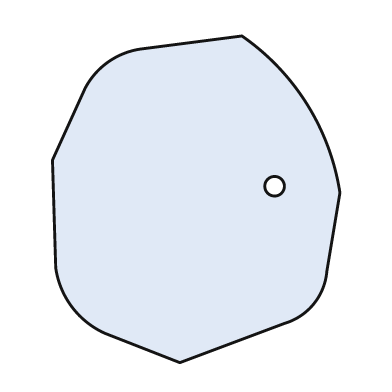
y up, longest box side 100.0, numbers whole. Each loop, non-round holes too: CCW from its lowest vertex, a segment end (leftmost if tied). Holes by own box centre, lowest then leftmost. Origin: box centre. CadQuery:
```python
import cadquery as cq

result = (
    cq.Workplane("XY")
    .moveTo(-5.0, -50.0)
    .lineTo(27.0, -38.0)
    .threePointArc((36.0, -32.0), (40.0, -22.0))
    .lineTo(44.0, 2.0)
    .threePointArc((34.0, 29.0), (14.0, 50.0))
    .lineTo(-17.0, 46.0)
    .threePointArc((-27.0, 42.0), (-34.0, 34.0))
    .lineTo(-44.0, 12.0)
    .lineTo(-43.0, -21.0)
    .threePointArc((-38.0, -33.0), (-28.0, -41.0))
    .close()
    .moveTo(24.0, 4.0)
    .circle(3.0)
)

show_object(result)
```